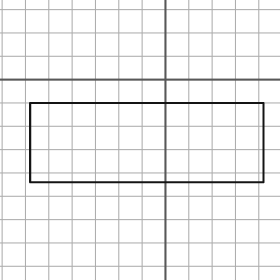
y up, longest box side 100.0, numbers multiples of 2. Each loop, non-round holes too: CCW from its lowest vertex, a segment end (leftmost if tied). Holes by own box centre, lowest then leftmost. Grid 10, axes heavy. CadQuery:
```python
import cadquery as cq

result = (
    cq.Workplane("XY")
    .moveTo(-58.0, -44.0)
    .lineTo(42.0, -44.0)
    .lineTo(42.0, -10.0)
    .lineTo(-58.0, -10.0)
    .close()
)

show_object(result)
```